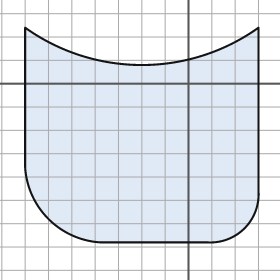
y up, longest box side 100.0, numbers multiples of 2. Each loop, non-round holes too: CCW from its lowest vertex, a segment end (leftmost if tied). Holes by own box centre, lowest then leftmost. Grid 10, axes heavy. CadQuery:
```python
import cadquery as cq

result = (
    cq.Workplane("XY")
    .moveTo(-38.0, -68.0)
    .lineTo(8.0, -68.0)
    .threePointArc((24.0, -62.0), (30.0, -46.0))
    .lineTo(30.0, 24.0)
    .threePointArc((-20.0, 8.0), (-70.0, 24.0))
    .lineTo(-70.0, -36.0)
    .threePointArc((-60.0, -58.0), (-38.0, -68.0))
    .close()
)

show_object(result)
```